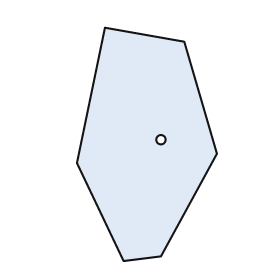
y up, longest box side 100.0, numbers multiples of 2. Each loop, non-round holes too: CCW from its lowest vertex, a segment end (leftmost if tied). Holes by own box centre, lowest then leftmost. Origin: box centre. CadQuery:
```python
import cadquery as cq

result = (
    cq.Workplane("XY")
    .moveTo(-10.0, -50.0)
    .lineTo(6.0, -48.0)
    .lineTo(30.0, -4.0)
    .lineTo(16.0, 44.0)
    .lineTo(-18.0, 50.0)
    .lineTo(-30.0, -8.0)
    .close()
    .moveTo(6.0, 2.0)
    .circle(2.0)
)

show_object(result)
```